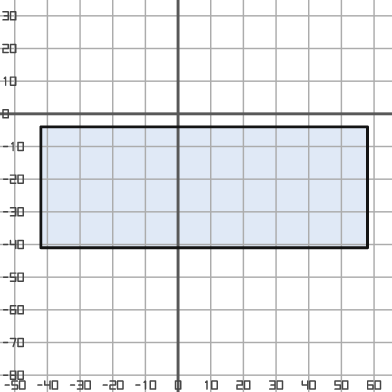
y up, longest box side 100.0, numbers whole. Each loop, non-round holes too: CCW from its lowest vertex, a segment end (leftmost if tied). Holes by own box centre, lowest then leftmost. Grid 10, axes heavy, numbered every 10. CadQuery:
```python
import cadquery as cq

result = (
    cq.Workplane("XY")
    .moveTo(-42.0, -41.0)
    .lineTo(58.0, -41.0)
    .lineTo(58.0, -4.0)
    .lineTo(-42.0, -4.0)
    .close()
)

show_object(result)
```